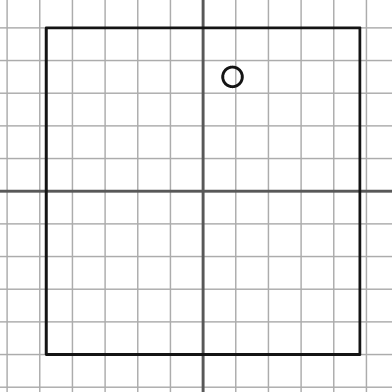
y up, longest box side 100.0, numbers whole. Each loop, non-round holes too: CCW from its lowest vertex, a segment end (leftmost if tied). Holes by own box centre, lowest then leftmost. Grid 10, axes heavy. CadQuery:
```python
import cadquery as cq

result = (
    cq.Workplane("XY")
    .moveTo(-48.0, -50.0)
    .lineTo(48.0, -50.0)
    .lineTo(48.0, 50.0)
    .lineTo(-48.0, 50.0)
    .close()
    .moveTo(9.0, 35.0)
    .circle(3.0)
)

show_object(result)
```